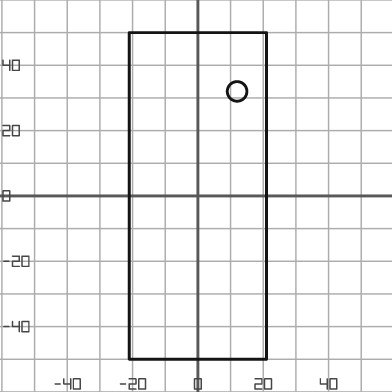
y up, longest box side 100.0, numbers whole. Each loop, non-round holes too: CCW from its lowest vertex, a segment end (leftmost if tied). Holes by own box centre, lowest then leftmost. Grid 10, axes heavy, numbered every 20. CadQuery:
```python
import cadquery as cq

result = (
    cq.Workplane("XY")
    .moveTo(-21.0, -50.0)
    .lineTo(21.0, -50.0)
    .lineTo(21.0, 50.0)
    .lineTo(-21.0, 50.0)
    .close()
    .moveTo(12.0, 32.0)
    .circle(3.0)
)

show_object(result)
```